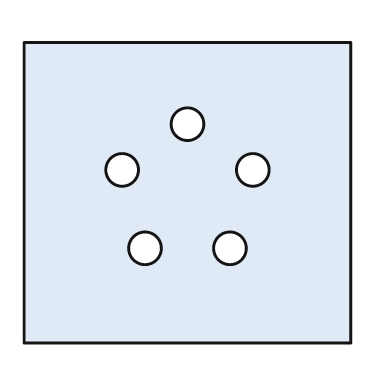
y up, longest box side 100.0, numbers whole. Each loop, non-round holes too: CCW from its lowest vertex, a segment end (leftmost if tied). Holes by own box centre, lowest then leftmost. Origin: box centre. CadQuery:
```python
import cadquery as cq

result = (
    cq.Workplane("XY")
    .moveTo(-50.0, -46.0)
    .lineTo(50.0, -46.0)
    .lineTo(50.0, 46.0)
    .lineTo(-50.0, 46.0)
    .close()
    .moveTo(-13.0, -17.0)
    .circle(5.0)
    .moveTo(13.0, -17.0)
    .circle(5.0)
    .moveTo(-20.0, 7.0)
    .circle(5.0)
    .moveTo(20.0, 7.0)
    .circle(5.0)
    .moveTo(0.0, 21.0)
    .circle(5.0)
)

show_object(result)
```